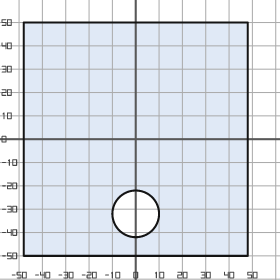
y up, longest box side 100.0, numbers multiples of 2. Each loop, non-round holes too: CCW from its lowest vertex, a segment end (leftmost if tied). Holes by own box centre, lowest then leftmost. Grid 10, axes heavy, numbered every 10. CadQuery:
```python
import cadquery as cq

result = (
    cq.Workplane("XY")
    .moveTo(-48.0, -50.0)
    .lineTo(48.0, -50.0)
    .lineTo(48.0, 50.0)
    .lineTo(-48.0, 50.0)
    .close()
    .moveTo(0.0, -32.0)
    .circle(10.0)
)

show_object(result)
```